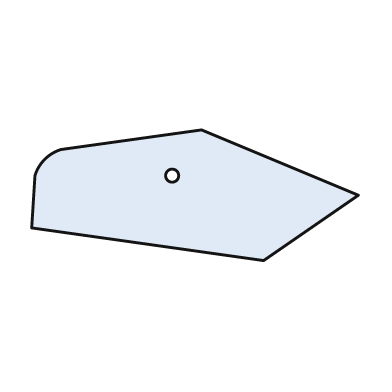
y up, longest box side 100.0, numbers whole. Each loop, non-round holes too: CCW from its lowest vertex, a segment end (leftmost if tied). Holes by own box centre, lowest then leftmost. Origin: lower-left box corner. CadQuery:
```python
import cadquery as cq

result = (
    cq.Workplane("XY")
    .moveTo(71.0, 0.0)
    .lineTo(100.0, 20.0)
    .lineTo(52.0, 40.0)
    .lineTo(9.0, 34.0)
    .threePointArc((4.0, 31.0), (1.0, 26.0))
    .lineTo(0.0, 10.0)
    .close()
    .moveTo(43.0, 26.0)
    .circle(2.0)
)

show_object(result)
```